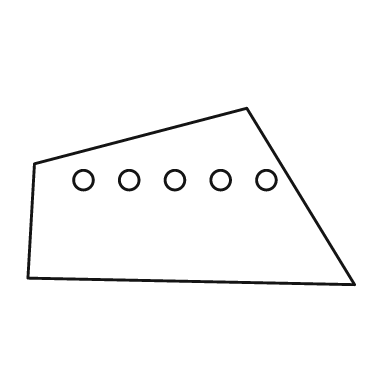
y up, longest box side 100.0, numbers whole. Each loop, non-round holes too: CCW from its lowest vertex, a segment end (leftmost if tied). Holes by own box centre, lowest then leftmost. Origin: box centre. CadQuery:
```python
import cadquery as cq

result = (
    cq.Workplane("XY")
    .moveTo(50.0, -27.0)
    .lineTo(17.0, 27.0)
    .lineTo(-48.0, 10.0)
    .lineTo(-50.0, -25.0)
    .close()
    .moveTo(-33.0, 5.0)
    .circle(3.0)
    .moveTo(-19.0, 5.0)
    .circle(3.0)
    .moveTo(-5.0, 5.0)
    .circle(3.0)
    .moveTo(9.0, 5.0)
    .circle(3.0)
    .moveTo(23.0, 5.0)
    .circle(3.0)
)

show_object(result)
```